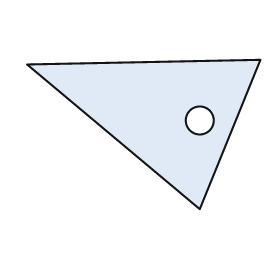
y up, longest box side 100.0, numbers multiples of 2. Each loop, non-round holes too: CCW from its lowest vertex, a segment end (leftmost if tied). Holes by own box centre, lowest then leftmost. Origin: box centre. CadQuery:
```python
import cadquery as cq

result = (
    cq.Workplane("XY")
    .moveTo(24.0, -32.0)
    .lineTo(50.0, 32.0)
    .lineTo(-50.0, 30.0)
    .close()
    .moveTo(24.0, 6.0)
    .circle(6.0)
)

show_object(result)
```